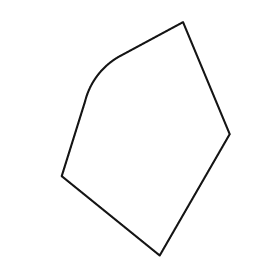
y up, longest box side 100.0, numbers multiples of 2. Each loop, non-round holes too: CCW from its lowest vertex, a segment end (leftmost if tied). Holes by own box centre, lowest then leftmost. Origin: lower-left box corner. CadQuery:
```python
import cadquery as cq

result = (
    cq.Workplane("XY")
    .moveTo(42.0, 0.0)
    .lineTo(72.0, 52.0)
    .lineTo(52.0, 100.0)
    .lineTo(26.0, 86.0)
    .threePointArc((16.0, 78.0), (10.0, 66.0))
    .lineTo(0.0, 34.0)
    .close()
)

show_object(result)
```